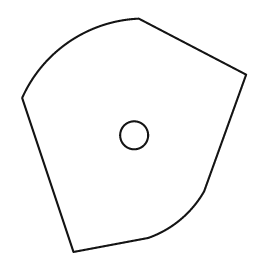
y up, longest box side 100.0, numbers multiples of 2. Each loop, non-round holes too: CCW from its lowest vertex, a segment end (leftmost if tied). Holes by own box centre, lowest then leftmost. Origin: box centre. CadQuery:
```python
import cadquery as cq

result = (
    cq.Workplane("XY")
    .moveTo(-26.0, -50.0)
    .lineTo(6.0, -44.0)
    .threePointArc((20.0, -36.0), (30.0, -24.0))
    .lineTo(48.0, 26.0)
    .lineTo(2.0, 50.0)
    .threePointArc((-28.0, 40.0), (-48.0, 16.0))
    .close()
    .moveTo(0.0, 0.0)
    .circle(6.0)
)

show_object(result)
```